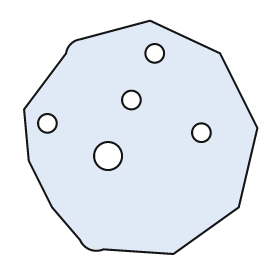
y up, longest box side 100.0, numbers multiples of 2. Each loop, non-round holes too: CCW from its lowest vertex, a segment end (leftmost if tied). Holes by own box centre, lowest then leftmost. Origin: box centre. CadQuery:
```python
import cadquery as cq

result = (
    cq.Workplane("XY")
    .moveTo(14.0, -50.0)
    .lineTo(42.0, -30.0)
    .lineTo(50.0, 4.0)
    .lineTo(34.0, 36.0)
    .lineTo(4.0, 50.0)
    .lineTo(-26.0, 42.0)
    .threePointArc((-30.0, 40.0), (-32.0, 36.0))
    .lineTo(-50.0, 12.0)
    .lineTo(-48.0, -10.0)
    .lineTo(-38.0, -30.0)
    .lineTo(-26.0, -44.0)
    .threePointArc((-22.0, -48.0), (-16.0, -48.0))
    .close()
    .moveTo(-14.0, -8.0)
    .circle(6.0)
    .moveTo(26.0, 2.0)
    .circle(4.0)
    .moveTo(-40.0, 6.0)
    .circle(4.0)
    .moveTo(-4.0, 16.0)
    .circle(4.0)
    .moveTo(6.0, 36.0)
    .circle(4.0)
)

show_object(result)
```